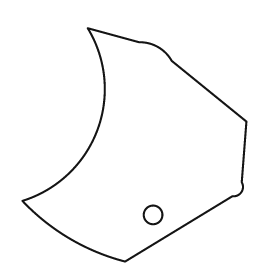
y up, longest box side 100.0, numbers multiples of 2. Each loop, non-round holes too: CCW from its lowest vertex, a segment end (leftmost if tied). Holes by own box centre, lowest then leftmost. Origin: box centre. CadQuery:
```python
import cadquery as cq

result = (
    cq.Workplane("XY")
    .moveTo(-4.0, -50.0)
    .lineTo(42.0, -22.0)
    .threePointArc((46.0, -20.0), (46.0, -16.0))
    .lineTo(48.0, 10.0)
    .lineTo(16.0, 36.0)
    .threePointArc((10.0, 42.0), (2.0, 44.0))
    .lineTo(-20.0, 50.0)
    .threePointArc((-16.0, 6.0), (-48.0, -24.0))
    .threePointArc((-28.0, -40.0), (-4.0, -50.0))
    .close()
    .moveTo(8.0, -30.0)
    .circle(4.0)
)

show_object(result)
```